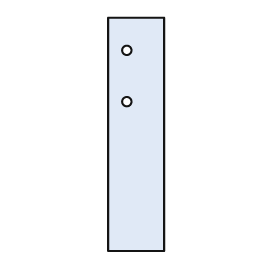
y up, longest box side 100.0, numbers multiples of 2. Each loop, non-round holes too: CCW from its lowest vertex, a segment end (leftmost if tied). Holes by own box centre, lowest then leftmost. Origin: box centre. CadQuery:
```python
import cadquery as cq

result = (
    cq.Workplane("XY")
    .moveTo(-12.0, -50.0)
    .lineTo(12.0, -50.0)
    .lineTo(12.0, 50.0)
    .lineTo(-12.0, 50.0)
    .close()
    .moveTo(-4.0, 14.0)
    .circle(2.0)
    .moveTo(-4.0, 36.0)
    .circle(2.0)
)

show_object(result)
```